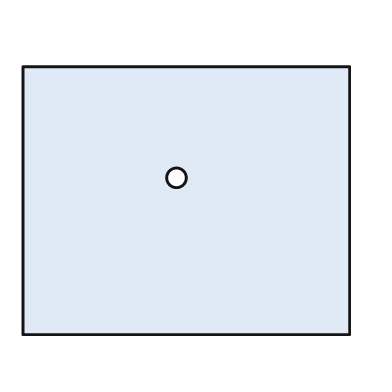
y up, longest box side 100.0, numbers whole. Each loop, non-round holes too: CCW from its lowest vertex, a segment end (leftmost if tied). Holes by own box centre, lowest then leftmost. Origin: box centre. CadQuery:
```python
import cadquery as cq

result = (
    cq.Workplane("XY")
    .moveTo(-50.0, -41.0)
    .lineTo(50.0, -41.0)
    .lineTo(50.0, 41.0)
    .lineTo(-50.0, 41.0)
    .close()
    .moveTo(-3.0, 7.0)
    .circle(3.0)
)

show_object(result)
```